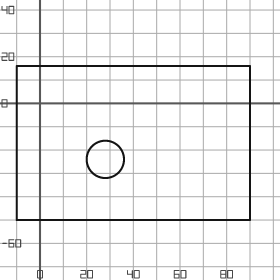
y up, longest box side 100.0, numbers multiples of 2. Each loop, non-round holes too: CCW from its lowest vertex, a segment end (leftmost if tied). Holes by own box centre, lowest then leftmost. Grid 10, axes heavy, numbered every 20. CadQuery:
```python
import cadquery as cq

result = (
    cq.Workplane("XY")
    .moveTo(-10.0, -50.0)
    .lineTo(90.0, -50.0)
    .lineTo(90.0, 16.0)
    .lineTo(-10.0, 16.0)
    .close()
    .moveTo(28.0, -24.0)
    .circle(8.0)
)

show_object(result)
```